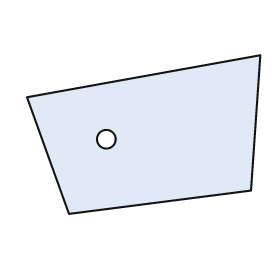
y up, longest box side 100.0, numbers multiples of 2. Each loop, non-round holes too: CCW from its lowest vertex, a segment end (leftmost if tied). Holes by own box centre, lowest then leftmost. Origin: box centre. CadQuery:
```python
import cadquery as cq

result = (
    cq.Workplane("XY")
    .moveTo(-32.0, -34.0)
    .lineTo(46.0, -24.0)
    .lineTo(50.0, 34.0)
    .lineTo(-50.0, 16.0)
    .close()
    .moveTo(-16.0, -2.0)
    .circle(4.0)
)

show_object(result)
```